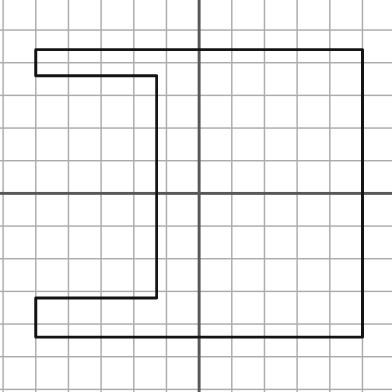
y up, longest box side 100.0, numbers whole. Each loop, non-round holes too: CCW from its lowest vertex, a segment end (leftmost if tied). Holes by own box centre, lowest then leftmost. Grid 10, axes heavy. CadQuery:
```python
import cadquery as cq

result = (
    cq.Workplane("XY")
    .moveTo(-50.0, -44.0)
    .lineTo(50.0, -44.0)
    .lineTo(50.0, 44.0)
    .lineTo(-50.0, 44.0)
    .lineTo(-50.0, 36.0)
    .lineTo(-13.0, 36.0)
    .lineTo(-13.0, -32.0)
    .lineTo(-50.0, -32.0)
    .close()
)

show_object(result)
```